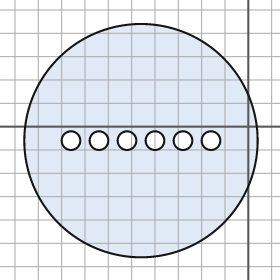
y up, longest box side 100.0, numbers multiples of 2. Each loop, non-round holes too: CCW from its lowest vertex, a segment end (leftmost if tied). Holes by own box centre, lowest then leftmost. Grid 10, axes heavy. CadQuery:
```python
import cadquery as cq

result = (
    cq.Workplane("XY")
    .moveTo(-46.0, -6.0)
    .circle(50.0)
    .moveTo(-76.0, -6.0)
    .circle(4.0)
    .moveTo(-64.0, -6.0)
    .circle(4.0)
    .moveTo(-52.0, -6.0)
    .circle(4.0)
    .moveTo(-40.0, -6.0)
    .circle(4.0)
    .moveTo(-28.0, -6.0)
    .circle(4.0)
    .moveTo(-16.0, -6.0)
    .circle(4.0)
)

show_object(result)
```